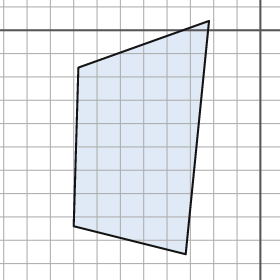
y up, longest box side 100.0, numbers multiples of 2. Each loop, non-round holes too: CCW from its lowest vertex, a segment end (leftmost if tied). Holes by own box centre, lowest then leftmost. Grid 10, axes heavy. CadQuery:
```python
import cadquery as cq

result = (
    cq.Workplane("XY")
    .moveTo(-32.0, -96.0)
    .lineTo(-22.0, 4.0)
    .lineTo(-78.0, -16.0)
    .lineTo(-80.0, -84.0)
    .close()
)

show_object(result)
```